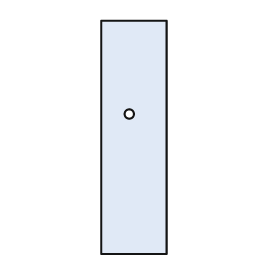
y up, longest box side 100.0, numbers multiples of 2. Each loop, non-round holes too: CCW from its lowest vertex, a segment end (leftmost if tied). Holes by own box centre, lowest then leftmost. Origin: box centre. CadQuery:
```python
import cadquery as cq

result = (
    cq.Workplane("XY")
    .moveTo(-14.0, -50.0)
    .lineTo(14.0, -50.0)
    .lineTo(14.0, 50.0)
    .lineTo(-14.0, 50.0)
    .close()
    .moveTo(-2.0, 10.0)
    .circle(2.0)
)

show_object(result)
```